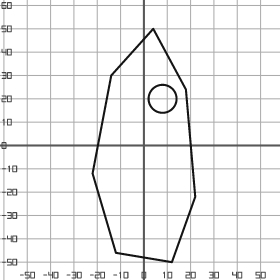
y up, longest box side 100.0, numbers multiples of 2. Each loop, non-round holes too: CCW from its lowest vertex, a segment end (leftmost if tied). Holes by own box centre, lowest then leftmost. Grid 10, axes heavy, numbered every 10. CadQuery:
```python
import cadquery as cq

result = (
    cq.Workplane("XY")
    .moveTo(12.0, -50.0)
    .lineTo(22.0, -22.0)
    .lineTo(18.0, 24.0)
    .lineTo(4.0, 50.0)
    .lineTo(-14.0, 30.0)
    .lineTo(-22.0, -12.0)
    .lineTo(-12.0, -46.0)
    .close()
    .moveTo(8.0, 20.0)
    .circle(6.0)
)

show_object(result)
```